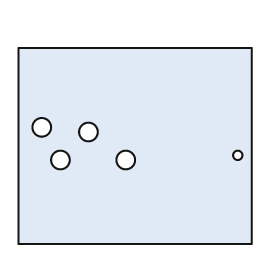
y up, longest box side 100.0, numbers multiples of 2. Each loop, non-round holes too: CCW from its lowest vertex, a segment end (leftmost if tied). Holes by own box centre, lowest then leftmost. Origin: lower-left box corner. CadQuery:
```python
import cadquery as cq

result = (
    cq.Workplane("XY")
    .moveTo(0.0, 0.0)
    .lineTo(100.0, 0.0)
    .lineTo(100.0, 84.0)
    .lineTo(0.0, 84.0)
    .close()
    .moveTo(18.0, 36.0)
    .circle(4.0)
    .moveTo(46.0, 36.0)
    .circle(4.0)
    .moveTo(94.0, 38.0)
    .circle(2.0)
    .moveTo(30.0, 48.0)
    .circle(4.0)
    .moveTo(10.0, 50.0)
    .circle(4.0)
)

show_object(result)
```